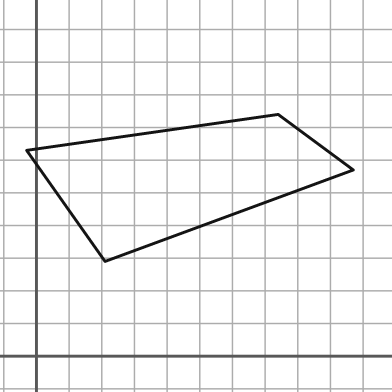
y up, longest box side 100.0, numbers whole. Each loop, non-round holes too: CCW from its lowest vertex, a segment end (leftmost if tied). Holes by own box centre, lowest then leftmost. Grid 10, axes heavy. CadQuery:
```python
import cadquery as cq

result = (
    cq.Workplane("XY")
    .moveTo(21.0, 29.0)
    .lineTo(97.0, 57.0)
    .lineTo(74.0, 74.0)
    .lineTo(-3.0, 63.0)
    .close()
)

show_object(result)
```